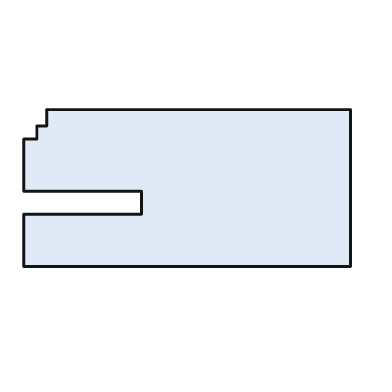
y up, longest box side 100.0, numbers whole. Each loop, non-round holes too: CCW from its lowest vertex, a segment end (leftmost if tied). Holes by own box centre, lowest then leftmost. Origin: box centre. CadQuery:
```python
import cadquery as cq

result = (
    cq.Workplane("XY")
    .moveTo(-50.0, -24.0)
    .lineTo(50.0, -24.0)
    .lineTo(50.0, 24.0)
    .lineTo(-43.0, 24.0)
    .lineTo(-43.0, 19.0)
    .lineTo(-46.0, 19.0)
    .lineTo(-46.0, 15.0)
    .lineTo(-50.0, 15.0)
    .lineTo(-50.0, -1.0)
    .lineTo(-14.0, -1.0)
    .lineTo(-14.0, -8.0)
    .lineTo(-50.0, -8.0)
    .close()
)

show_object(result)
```